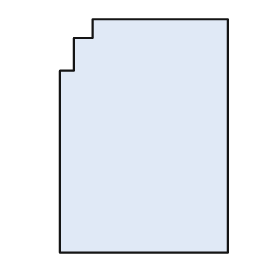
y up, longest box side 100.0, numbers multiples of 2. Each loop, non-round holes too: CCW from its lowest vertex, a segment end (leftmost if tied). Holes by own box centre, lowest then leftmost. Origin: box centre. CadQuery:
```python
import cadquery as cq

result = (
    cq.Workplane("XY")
    .moveTo(-36.0, -50.0)
    .lineTo(36.0, -50.0)
    .lineTo(36.0, 50.0)
    .lineTo(-22.0, 50.0)
    .lineTo(-22.0, 42.0)
    .lineTo(-30.0, 42.0)
    .lineTo(-30.0, 28.0)
    .lineTo(-36.0, 28.0)
    .close()
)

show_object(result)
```